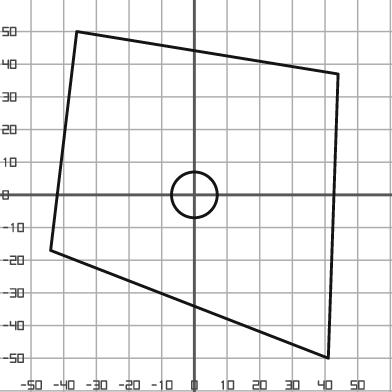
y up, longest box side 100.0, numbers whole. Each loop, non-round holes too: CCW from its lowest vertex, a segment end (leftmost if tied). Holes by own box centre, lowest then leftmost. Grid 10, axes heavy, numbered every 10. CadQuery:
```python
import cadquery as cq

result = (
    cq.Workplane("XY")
    .moveTo(41.0, -50.0)
    .lineTo(44.0, 37.0)
    .lineTo(-36.0, 50.0)
    .lineTo(-44.0, -17.0)
    .close()
    .moveTo(0.0, 0.0)
    .circle(7.0)
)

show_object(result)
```